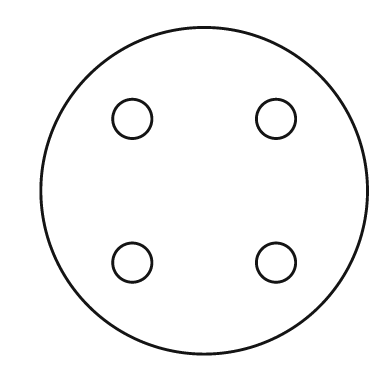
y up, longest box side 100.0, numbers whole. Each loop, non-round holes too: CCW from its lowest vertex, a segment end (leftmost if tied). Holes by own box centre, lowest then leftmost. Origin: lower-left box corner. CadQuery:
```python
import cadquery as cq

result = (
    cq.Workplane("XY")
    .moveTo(50.0, 50.0)
    .circle(50.0)
    .moveTo(28.0, 28.0)
    .circle(6.0)
    .moveTo(72.0, 28.0)
    .circle(6.0)
    .moveTo(28.0, 72.0)
    .circle(6.0)
    .moveTo(72.0, 72.0)
    .circle(6.0)
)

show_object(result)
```